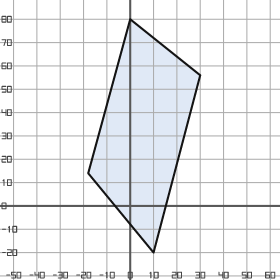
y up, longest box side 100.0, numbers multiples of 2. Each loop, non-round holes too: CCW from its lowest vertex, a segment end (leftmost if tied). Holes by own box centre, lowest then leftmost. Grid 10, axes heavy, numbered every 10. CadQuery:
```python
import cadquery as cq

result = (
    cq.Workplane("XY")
    .moveTo(10.0, -20.0)
    .lineTo(30.0, 56.0)
    .lineTo(0.0, 80.0)
    .lineTo(-18.0, 14.0)
    .close()
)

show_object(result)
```